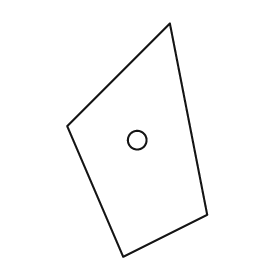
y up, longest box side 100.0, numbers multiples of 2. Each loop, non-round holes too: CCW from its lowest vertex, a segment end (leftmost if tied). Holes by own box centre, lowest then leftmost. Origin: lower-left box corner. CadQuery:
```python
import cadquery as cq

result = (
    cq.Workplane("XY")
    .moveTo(24.0, 0.0)
    .lineTo(60.0, 18.0)
    .lineTo(44.0, 100.0)
    .lineTo(0.0, 56.0)
    .close()
    .moveTo(30.0, 50.0)
    .circle(4.0)
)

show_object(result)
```